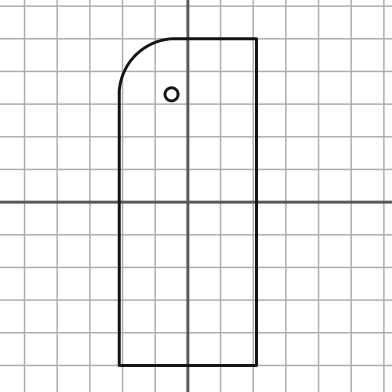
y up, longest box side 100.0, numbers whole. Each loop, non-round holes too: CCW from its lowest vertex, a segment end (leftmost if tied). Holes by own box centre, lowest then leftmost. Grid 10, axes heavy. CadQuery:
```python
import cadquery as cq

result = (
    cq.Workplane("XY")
    .moveTo(-21.0, -50.0)
    .lineTo(21.0, -50.0)
    .lineTo(21.0, 50.0)
    .lineTo(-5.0, 50.0)
    .threePointArc((-16.0, 45.0), (-21.0, 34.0))
    .close()
    .moveTo(-5.0, 33.0)
    .circle(2.0)
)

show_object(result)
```